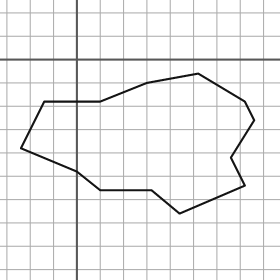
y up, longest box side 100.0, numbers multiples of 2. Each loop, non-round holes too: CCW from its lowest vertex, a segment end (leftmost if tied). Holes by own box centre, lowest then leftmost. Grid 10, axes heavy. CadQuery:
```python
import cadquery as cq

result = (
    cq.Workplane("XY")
    .moveTo(44.0, -66.0)
    .lineTo(72.0, -54.0)
    .lineTo(66.0, -42.0)
    .lineTo(76.0, -26.0)
    .lineTo(72.0, -18.0)
    .lineTo(52.0, -6.0)
    .lineTo(30.0, -10.0)
    .lineTo(10.0, -18.0)
    .lineTo(-14.0, -18.0)
    .lineTo(-24.0, -38.0)
    .lineTo(0.0, -48.0)
    .lineTo(10.0, -56.0)
    .lineTo(32.0, -56.0)
    .close()
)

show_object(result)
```